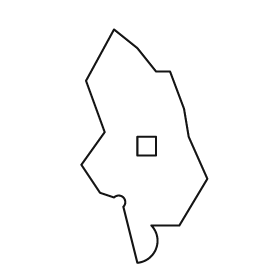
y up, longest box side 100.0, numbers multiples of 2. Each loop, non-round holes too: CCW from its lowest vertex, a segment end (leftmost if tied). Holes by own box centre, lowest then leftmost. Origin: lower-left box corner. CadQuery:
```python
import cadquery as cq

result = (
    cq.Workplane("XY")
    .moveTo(24.0, 0.0)
    .threePointArc((32.0, 6.0), (30.0, 16.0))
    .lineTo(42.0, 16.0)
    .lineTo(54.0, 36.0)
    .lineTo(46.0, 54.0)
    .lineTo(44.0, 66.0)
    .lineTo(38.0, 82.0)
    .lineTo(32.0, 82.0)
    .lineTo(24.0, 92.0)
    .lineTo(14.0, 100.0)
    .lineTo(2.0, 78.0)
    .lineTo(10.0, 56.0)
    .lineTo(0.0, 42.0)
    .lineTo(8.0, 30.0)
    .lineTo(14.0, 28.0)
    .threePointArc((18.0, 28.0), (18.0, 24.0))
    .close()
    .moveTo(24.0, 46.0)
    .lineTo(32.0, 46.0)
    .lineTo(32.0, 54.0)
    .lineTo(24.0, 54.0)
    .close()
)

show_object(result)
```